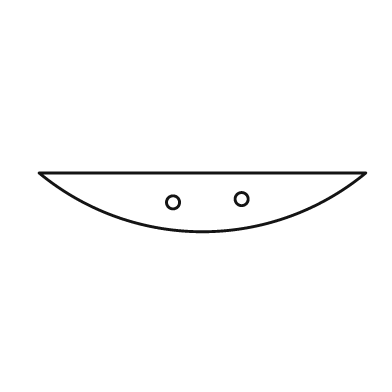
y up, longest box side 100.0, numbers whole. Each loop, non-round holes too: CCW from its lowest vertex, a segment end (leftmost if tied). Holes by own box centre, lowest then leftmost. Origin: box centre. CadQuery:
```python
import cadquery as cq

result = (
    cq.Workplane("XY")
    .moveTo(-50.0, 9.0)
    .threePointArc((0.0, -9.0), (50.0, 9.0))
    .close()
    .moveTo(-9.0, 0.0)
    .circle(2.0)
    .moveTo(12.0, 1.0)
    .circle(2.0)
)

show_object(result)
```